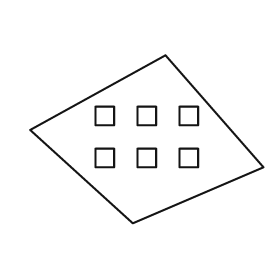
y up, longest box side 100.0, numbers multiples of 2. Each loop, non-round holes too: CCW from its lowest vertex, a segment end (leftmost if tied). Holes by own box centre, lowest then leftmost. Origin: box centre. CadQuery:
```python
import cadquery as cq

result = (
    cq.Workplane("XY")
    .moveTo(-6.0, -36.0)
    .lineTo(50.0, -12.0)
    .lineTo(8.0, 36.0)
    .lineTo(-50.0, 4.0)
    .close()
    .moveTo(-22.0, -12.0)
    .lineTo(-14.0, -12.0)
    .lineTo(-14.0, -4.0)
    .lineTo(-22.0, -4.0)
    .close()
    .moveTo(-4.0, -12.0)
    .lineTo(4.0, -12.0)
    .lineTo(4.0, -4.0)
    .lineTo(-4.0, -4.0)
    .close()
    .moveTo(14.0, -12.0)
    .lineTo(22.0, -12.0)
    .lineTo(22.0, -4.0)
    .lineTo(14.0, -4.0)
    .close()
    .moveTo(-22.0, 6.0)
    .lineTo(-14.0, 6.0)
    .lineTo(-14.0, 14.0)
    .lineTo(-22.0, 14.0)
    .close()
    .moveTo(-4.0, 6.0)
    .lineTo(4.0, 6.0)
    .lineTo(4.0, 14.0)
    .lineTo(-4.0, 14.0)
    .close()
    .moveTo(14.0, 6.0)
    .lineTo(22.0, 6.0)
    .lineTo(22.0, 14.0)
    .lineTo(14.0, 14.0)
    .close()
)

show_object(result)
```